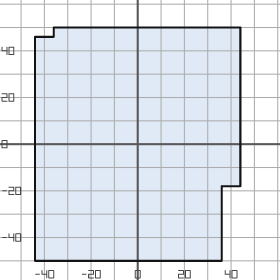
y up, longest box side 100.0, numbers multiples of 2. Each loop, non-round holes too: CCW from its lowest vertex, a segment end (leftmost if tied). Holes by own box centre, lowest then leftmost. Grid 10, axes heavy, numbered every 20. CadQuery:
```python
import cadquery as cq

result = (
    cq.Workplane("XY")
    .moveTo(-44.0, -50.0)
    .lineTo(36.0, -50.0)
    .lineTo(36.0, -18.0)
    .lineTo(44.0, -18.0)
    .lineTo(44.0, 50.0)
    .lineTo(-36.0, 50.0)
    .lineTo(-36.0, 46.0)
    .lineTo(-44.0, 46.0)
    .close()
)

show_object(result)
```